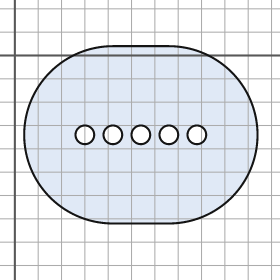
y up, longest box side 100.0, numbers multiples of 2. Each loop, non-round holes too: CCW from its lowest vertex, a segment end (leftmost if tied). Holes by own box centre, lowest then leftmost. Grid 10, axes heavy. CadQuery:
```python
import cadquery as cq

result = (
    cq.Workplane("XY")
    .moveTo(42.0, -72.0)
    .lineTo(66.0, -72.0)
    .threePointArc((104.0, -34.0), (66.0, 4.0))
    .lineTo(42.0, 4.0)
    .threePointArc((4.0, -34.0), (42.0, -72.0))
    .close()
    .moveTo(30.0, -34.0)
    .circle(4.0)
    .moveTo(42.0, -34.0)
    .circle(4.0)
    .moveTo(54.0, -34.0)
    .circle(4.0)
    .moveTo(66.0, -34.0)
    .circle(4.0)
    .moveTo(78.0, -34.0)
    .circle(4.0)
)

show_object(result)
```